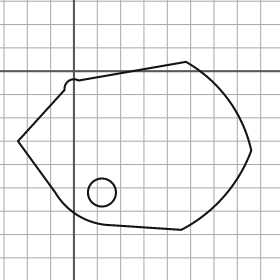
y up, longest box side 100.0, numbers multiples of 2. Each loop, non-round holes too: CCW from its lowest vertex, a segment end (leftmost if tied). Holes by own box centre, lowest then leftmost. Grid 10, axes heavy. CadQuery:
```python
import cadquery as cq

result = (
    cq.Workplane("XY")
    .moveTo(46.0, -68.0)
    .threePointArc((64.0, -54.0), (76.0, -34.0))
    .threePointArc((66.0, -12.0), (48.0, 4.0))
    .lineTo(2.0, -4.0)
    .threePointArc((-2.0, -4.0), (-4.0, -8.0))
    .lineTo(-24.0, -30.0)
    .lineTo(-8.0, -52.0)
    .threePointArc((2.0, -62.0), (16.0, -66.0))
    .close()
    .moveTo(12.0, -52.0)
    .circle(6.0)
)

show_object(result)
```